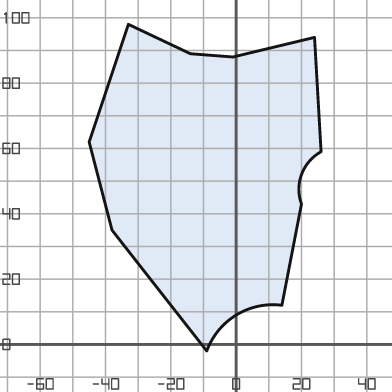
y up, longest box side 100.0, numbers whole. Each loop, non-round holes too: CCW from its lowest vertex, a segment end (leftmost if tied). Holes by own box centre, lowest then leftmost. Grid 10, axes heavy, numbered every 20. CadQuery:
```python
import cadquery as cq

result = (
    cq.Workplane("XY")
    .moveTo(-9.0, -2.0)
    .threePointArc((0.0, 9.0), (14.0, 12.0))
    .lineTo(20.0, 43.0)
    .threePointArc((20.0, 52.0), (26.0, 59.0))
    .lineTo(24.0, 94.0)
    .lineTo(-1.0, 88.0)
    .lineTo(-14.0, 89.0)
    .lineTo(-33.0, 98.0)
    .lineTo(-45.0, 62.0)
    .lineTo(-38.0, 35.0)
    .close()
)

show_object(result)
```